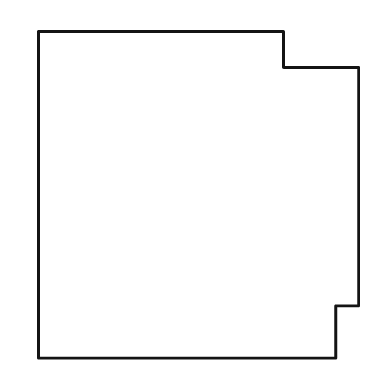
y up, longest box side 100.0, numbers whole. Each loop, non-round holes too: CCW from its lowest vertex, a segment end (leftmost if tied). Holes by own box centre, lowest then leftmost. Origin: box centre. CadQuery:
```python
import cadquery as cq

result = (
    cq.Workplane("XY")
    .moveTo(-49.0, -50.0)
    .lineTo(42.0, -50.0)
    .lineTo(42.0, -34.0)
    .lineTo(49.0, -34.0)
    .lineTo(49.0, 39.0)
    .lineTo(26.0, 39.0)
    .lineTo(26.0, 50.0)
    .lineTo(-49.0, 50.0)
    .close()
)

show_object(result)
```